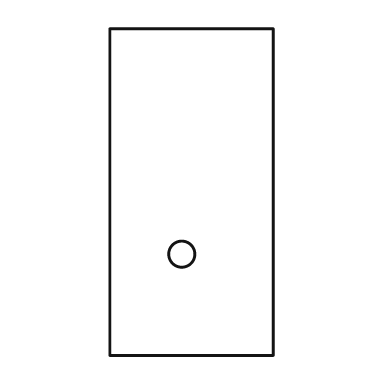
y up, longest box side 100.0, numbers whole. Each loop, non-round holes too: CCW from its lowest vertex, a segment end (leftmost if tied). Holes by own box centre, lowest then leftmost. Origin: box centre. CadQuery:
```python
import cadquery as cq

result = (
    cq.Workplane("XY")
    .moveTo(-25.0, -50.0)
    .lineTo(25.0, -50.0)
    .lineTo(25.0, 50.0)
    .lineTo(-25.0, 50.0)
    .close()
    .moveTo(-3.0, -19.0)
    .circle(4.0)
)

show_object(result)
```